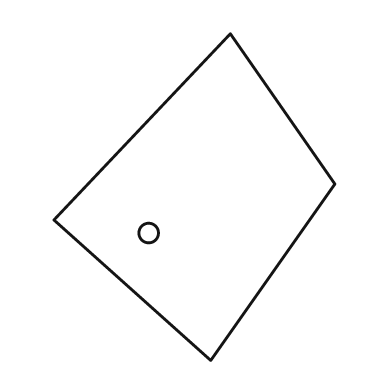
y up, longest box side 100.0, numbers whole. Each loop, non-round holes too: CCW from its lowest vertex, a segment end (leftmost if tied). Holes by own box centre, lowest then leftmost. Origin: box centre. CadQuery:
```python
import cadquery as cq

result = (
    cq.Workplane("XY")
    .moveTo(5.0, -50.0)
    .lineTo(43.0, 4.0)
    .lineTo(11.0, 50.0)
    .lineTo(-43.0, -7.0)
    .close()
    .moveTo(-14.0, -11.0)
    .circle(3.0)
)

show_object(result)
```